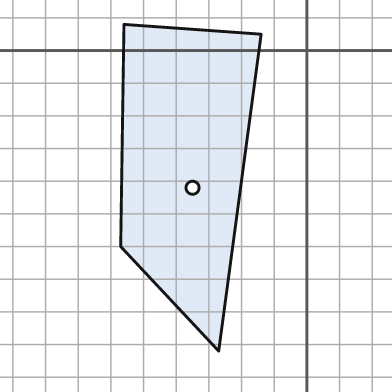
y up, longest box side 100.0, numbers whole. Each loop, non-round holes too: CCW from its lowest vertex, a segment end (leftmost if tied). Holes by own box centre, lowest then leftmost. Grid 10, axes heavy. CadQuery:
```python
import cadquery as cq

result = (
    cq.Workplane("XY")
    .moveTo(-27.0, -92.0)
    .lineTo(-14.0, 5.0)
    .lineTo(-56.0, 8.0)
    .lineTo(-57.0, -60.0)
    .close()
    .moveTo(-35.0, -42.0)
    .circle(2.0)
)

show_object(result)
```